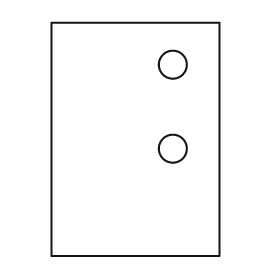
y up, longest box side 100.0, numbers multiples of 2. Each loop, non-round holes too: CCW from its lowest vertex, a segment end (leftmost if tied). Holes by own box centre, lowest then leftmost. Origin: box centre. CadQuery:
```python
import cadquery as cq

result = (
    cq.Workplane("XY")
    .moveTo(-36.0, -50.0)
    .lineTo(36.0, -50.0)
    .lineTo(36.0, 50.0)
    .lineTo(-36.0, 50.0)
    .close()
    .moveTo(16.0, -4.0)
    .circle(6.0)
    .moveTo(16.0, 32.0)
    .circle(6.0)
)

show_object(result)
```